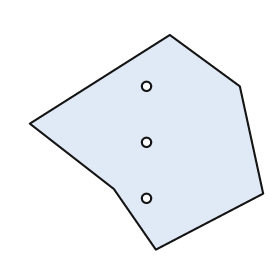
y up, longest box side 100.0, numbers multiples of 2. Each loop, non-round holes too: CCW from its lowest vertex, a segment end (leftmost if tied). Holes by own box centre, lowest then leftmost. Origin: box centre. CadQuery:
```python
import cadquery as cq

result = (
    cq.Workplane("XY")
    .moveTo(4.0, -46.0)
    .lineTo(50.0, -22.0)
    .lineTo(40.0, 24.0)
    .lineTo(10.0, 46.0)
    .lineTo(-50.0, 8.0)
    .lineTo(-14.0, -20.0)
    .close()
    .moveTo(0.0, -24.0)
    .circle(2.0)
    .moveTo(0.0, 0.0)
    .circle(2.0)
    .moveTo(0.0, 24.0)
    .circle(2.0)
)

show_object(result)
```